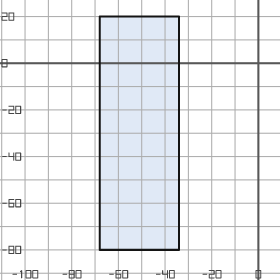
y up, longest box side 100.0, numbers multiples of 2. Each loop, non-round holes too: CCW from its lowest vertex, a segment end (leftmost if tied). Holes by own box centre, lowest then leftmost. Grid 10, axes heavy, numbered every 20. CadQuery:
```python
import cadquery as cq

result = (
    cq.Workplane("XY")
    .moveTo(-68.0, -80.0)
    .lineTo(-34.0, -80.0)
    .lineTo(-34.0, 20.0)
    .lineTo(-68.0, 20.0)
    .close()
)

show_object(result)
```